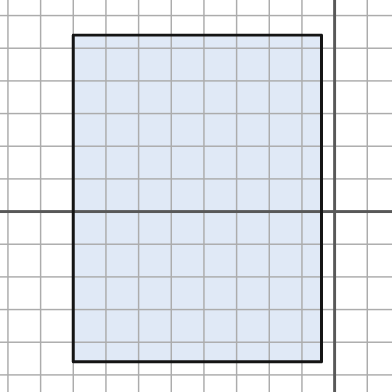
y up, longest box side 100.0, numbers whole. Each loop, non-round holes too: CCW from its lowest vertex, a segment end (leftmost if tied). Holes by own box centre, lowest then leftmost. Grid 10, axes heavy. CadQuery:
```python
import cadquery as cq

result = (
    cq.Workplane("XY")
    .moveTo(-80.0, -46.0)
    .lineTo(-4.0, -46.0)
    .lineTo(-4.0, 54.0)
    .lineTo(-80.0, 54.0)
    .close()
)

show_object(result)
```